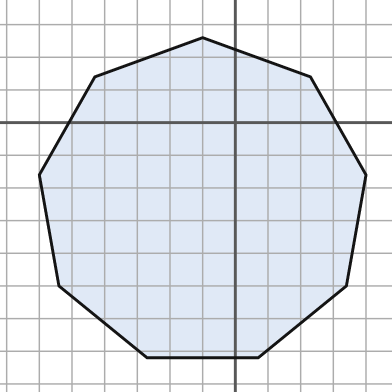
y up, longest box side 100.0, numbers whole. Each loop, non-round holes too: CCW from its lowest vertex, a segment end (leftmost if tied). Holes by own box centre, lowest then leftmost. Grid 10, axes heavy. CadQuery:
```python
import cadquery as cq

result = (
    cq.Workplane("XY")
    .moveTo(-27.0, -72.0)
    .lineTo(7.0, -72.0)
    .lineTo(34.0, -50.0)
    .lineTo(40.0, -16.0)
    .lineTo(23.0, 14.0)
    .lineTo(-10.0, 26.0)
    .lineTo(-43.0, 14.0)
    .lineTo(-60.0, -16.0)
    .lineTo(-54.0, -50.0)
    .close()
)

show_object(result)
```